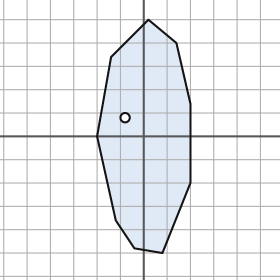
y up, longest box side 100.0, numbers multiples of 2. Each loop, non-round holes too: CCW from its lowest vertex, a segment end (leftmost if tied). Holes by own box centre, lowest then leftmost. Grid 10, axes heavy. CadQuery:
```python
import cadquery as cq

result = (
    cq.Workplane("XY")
    .moveTo(8.0, -50.0)
    .lineTo(20.0, -20.0)
    .lineTo(20.0, 14.0)
    .lineTo(14.0, 40.0)
    .lineTo(2.0, 50.0)
    .lineTo(-14.0, 34.0)
    .lineTo(-20.0, 0.0)
    .lineTo(-12.0, -36.0)
    .lineTo(-4.0, -48.0)
    .close()
    .moveTo(-8.0, 8.0)
    .circle(2.0)
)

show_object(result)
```